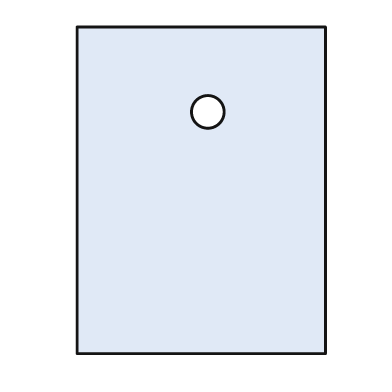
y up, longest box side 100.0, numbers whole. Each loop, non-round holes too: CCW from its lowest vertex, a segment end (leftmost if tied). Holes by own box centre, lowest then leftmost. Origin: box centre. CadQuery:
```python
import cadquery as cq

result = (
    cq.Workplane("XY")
    .moveTo(-38.0, -50.0)
    .lineTo(38.0, -50.0)
    .lineTo(38.0, 50.0)
    .lineTo(-38.0, 50.0)
    .close()
    .moveTo(2.0, 24.0)
    .circle(5.0)
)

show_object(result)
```